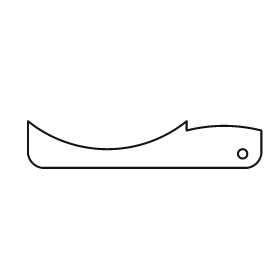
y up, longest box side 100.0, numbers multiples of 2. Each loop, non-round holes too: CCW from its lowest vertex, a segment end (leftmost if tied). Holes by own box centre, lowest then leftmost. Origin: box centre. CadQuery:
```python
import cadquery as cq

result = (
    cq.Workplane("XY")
    .moveTo(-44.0, -10.0)
    .lineTo(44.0, -10.0)
    .threePointArc((48.0, -8.0), (50.0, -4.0))
    .lineTo(50.0, 6.0)
    .threePointArc((34.0, 8.0), (18.0, 6.0))
    .lineTo(18.0, 10.0)
    .threePointArc((-16.0, -2.0), (-50.0, 10.0))
    .lineTo(-50.0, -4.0)
    .threePointArc((-48.0, -8.0), (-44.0, -10.0))
    .close()
    .moveTo(42.0, -4.0)
    .circle(2.0)
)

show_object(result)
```